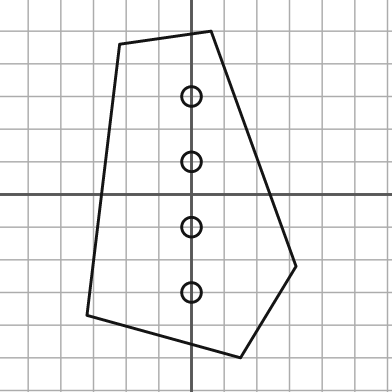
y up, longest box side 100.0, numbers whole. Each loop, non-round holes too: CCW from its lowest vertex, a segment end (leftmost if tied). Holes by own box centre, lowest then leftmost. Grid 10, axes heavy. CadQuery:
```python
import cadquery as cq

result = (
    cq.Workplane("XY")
    .moveTo(15.0, -50.0)
    .lineTo(32.0, -22.0)
    .lineTo(6.0, 50.0)
    .lineTo(-22.0, 46.0)
    .lineTo(-32.0, -37.0)
    .close()
    .moveTo(0.0, -30.0)
    .circle(3.0)
    .moveTo(0.0, -10.0)
    .circle(3.0)
    .moveTo(0.0, 10.0)
    .circle(3.0)
    .moveTo(0.0, 30.0)
    .circle(3.0)
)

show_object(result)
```